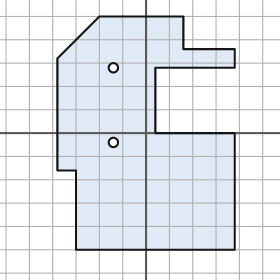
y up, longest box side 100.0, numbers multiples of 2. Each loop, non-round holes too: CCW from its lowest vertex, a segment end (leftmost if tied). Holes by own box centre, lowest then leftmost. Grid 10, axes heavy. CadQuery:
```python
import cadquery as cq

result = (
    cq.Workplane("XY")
    .moveTo(-30.0, -50.0)
    .lineTo(38.0, -50.0)
    .lineTo(38.0, 0.0)
    .lineTo(4.0, 0.0)
    .lineTo(4.0, 28.0)
    .lineTo(38.0, 28.0)
    .lineTo(38.0, 36.0)
    .lineTo(16.0, 36.0)
    .lineTo(16.0, 50.0)
    .lineTo(-20.0, 50.0)
    .lineTo(-38.0, 32.0)
    .lineTo(-38.0, -16.0)
    .lineTo(-30.0, -16.0)
    .close()
    .moveTo(-14.0, -4.0)
    .circle(2.0)
    .moveTo(-14.0, 28.0)
    .circle(2.0)
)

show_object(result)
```